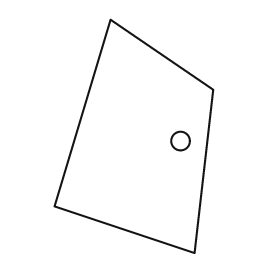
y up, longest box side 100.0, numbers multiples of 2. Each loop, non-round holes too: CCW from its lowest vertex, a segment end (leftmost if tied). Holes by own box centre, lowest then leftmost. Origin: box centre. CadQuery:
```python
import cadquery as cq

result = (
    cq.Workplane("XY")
    .moveTo(26.0, -50.0)
    .lineTo(34.0, 20.0)
    .lineTo(-10.0, 50.0)
    .lineTo(-34.0, -30.0)
    .close()
    .moveTo(20.0, -2.0)
    .circle(4.0)
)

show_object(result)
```